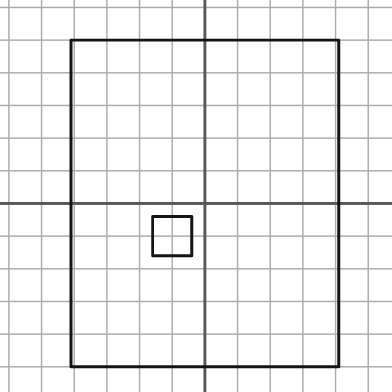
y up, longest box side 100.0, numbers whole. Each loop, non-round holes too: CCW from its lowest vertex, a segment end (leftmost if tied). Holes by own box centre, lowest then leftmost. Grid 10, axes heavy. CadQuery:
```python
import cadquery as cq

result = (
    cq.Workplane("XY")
    .moveTo(-41.0, -50.0)
    .lineTo(41.0, -50.0)
    .lineTo(41.0, 50.0)
    .lineTo(-41.0, 50.0)
    .close()
    .moveTo(-16.0, -16.0)
    .lineTo(-4.0, -16.0)
    .lineTo(-4.0, -4.0)
    .lineTo(-16.0, -4.0)
    .close()
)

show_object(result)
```